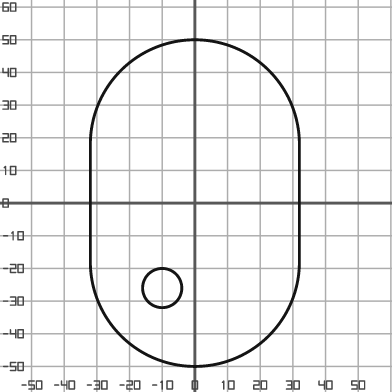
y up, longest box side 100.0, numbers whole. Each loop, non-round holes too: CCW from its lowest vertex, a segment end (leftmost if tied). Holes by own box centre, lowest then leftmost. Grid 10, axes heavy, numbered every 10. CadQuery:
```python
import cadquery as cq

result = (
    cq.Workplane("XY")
    .moveTo(-32.0, -18.0)
    .threePointArc((0.0, -50.0), (32.0, -18.0))
    .lineTo(32.0, 18.0)
    .threePointArc((0.0, 50.0), (-32.0, 18.0))
    .close()
    .moveTo(-10.0, -26.0)
    .circle(6.0)
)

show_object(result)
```